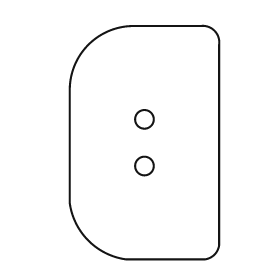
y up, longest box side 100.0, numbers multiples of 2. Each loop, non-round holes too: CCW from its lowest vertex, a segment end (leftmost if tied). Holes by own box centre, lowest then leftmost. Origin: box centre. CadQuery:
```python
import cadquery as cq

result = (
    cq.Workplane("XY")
    .moveTo(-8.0, -50.0)
    .lineTo(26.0, -50.0)
    .threePointArc((30.0, -48.0), (32.0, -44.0))
    .lineTo(32.0, 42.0)
    .threePointArc((30.0, 48.0), (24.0, 50.0))
    .lineTo(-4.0, 50.0)
    .threePointArc((-24.0, 42.0), (-32.0, 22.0))
    .lineTo(-32.0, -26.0)
    .threePointArc((-24.0, -42.0), (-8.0, -50.0))
    .close()
    .moveTo(0.0, -10.0)
    .circle(4.0)
    .moveTo(0.0, 10.0)
    .circle(4.0)
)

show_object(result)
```